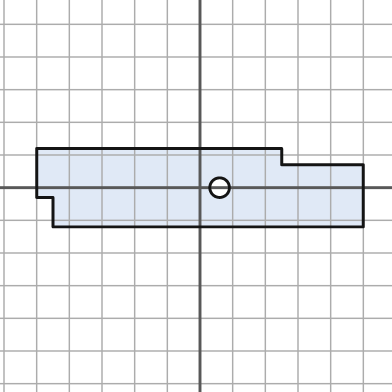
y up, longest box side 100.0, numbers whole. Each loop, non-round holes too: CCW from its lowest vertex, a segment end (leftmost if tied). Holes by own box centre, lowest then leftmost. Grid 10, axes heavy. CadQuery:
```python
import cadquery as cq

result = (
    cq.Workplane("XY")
    .moveTo(-45.0, -12.0)
    .lineTo(50.0, -12.0)
    .lineTo(50.0, 7.0)
    .lineTo(25.0, 7.0)
    .lineTo(25.0, 12.0)
    .lineTo(-50.0, 12.0)
    .lineTo(-50.0, -3.0)
    .lineTo(-45.0, -3.0)
    .close()
    .moveTo(6.0, 0.0)
    .circle(3.0)
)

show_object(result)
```